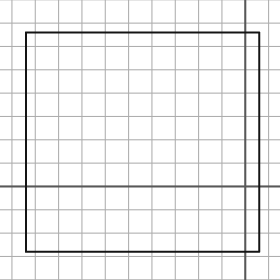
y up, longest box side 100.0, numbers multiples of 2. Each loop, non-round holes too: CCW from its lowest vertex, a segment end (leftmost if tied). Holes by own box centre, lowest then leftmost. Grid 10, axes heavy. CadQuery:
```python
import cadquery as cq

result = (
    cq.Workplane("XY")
    .moveTo(-94.0, -28.0)
    .lineTo(6.0, -28.0)
    .lineTo(6.0, 66.0)
    .lineTo(-94.0, 66.0)
    .close()
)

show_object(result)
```